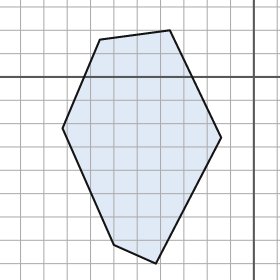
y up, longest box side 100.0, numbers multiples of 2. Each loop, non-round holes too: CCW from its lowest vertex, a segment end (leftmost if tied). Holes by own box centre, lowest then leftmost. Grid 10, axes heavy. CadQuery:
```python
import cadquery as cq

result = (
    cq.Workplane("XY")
    .moveTo(-42.0, -80.0)
    .lineTo(-14.0, -26.0)
    .lineTo(-36.0, 20.0)
    .lineTo(-66.0, 16.0)
    .lineTo(-82.0, -22.0)
    .lineTo(-60.0, -72.0)
    .close()
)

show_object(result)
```